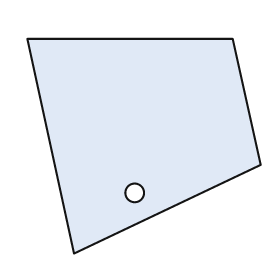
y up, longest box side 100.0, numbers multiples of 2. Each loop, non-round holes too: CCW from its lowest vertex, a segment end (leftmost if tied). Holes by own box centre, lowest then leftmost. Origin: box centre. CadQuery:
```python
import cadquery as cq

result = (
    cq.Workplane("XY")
    .moveTo(-30.0, -46.0)
    .lineTo(50.0, -8.0)
    .lineTo(38.0, 46.0)
    .lineTo(-50.0, 46.0)
    .close()
    .moveTo(-4.0, -20.0)
    .circle(4.0)
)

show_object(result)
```